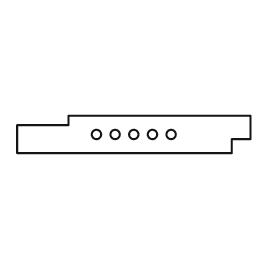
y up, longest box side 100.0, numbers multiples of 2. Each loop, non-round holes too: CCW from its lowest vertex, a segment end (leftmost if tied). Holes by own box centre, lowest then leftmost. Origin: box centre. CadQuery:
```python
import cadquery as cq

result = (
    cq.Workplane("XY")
    .moveTo(-50.0, -8.0)
    .lineTo(42.0, -8.0)
    .lineTo(42.0, -2.0)
    .lineTo(50.0, -2.0)
    .lineTo(50.0, 8.0)
    .lineTo(-28.0, 8.0)
    .lineTo(-28.0, 4.0)
    .lineTo(-50.0, 4.0)
    .close()
    .moveTo(-16.0, 0.0)
    .circle(2.0)
    .moveTo(-8.0, 0.0)
    .circle(2.0)
    .moveTo(0.0, 0.0)
    .circle(2.0)
    .moveTo(8.0, 0.0)
    .circle(2.0)
    .moveTo(16.0, 0.0)
    .circle(2.0)
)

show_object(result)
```